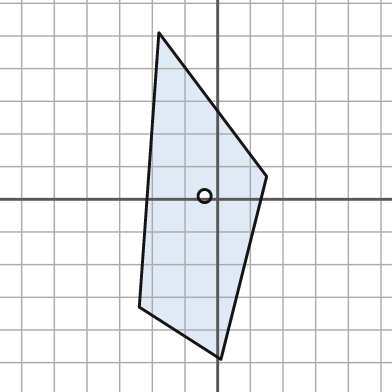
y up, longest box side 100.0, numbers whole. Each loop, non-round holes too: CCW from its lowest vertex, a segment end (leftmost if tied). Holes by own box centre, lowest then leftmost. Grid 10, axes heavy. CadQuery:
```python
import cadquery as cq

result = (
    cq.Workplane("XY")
    .moveTo(1.0, -49.0)
    .lineTo(15.0, 7.0)
    .lineTo(-18.0, 51.0)
    .lineTo(-24.0, -33.0)
    .close()
    .moveTo(-4.0, 1.0)
    .circle(2.0)
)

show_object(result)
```